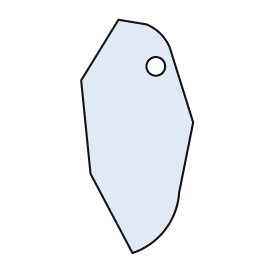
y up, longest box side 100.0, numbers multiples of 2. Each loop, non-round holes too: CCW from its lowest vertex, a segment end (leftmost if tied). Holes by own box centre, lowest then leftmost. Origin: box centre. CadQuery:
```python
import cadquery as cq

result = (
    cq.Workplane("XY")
    .moveTo(-2.0, -50.0)
    .threePointArc((12.0, -40.0), (18.0, -24.0))
    .lineTo(24.0, 6.0)
    .lineTo(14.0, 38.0)
    .threePointArc((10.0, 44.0), (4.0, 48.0))
    .lineTo(-8.0, 50.0)
    .lineTo(-24.0, 24.0)
    .lineTo(-20.0, -16.0)
    .close()
    .moveTo(8.0, 30.0)
    .circle(4.0)
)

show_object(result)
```